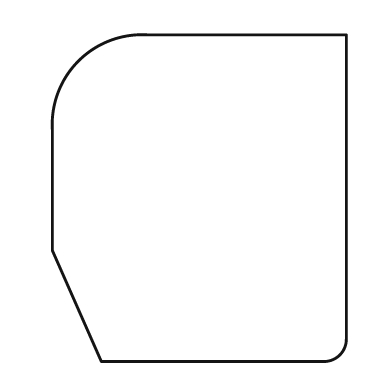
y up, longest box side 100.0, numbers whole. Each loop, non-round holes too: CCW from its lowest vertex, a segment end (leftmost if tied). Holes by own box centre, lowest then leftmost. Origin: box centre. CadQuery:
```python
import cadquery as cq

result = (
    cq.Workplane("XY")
    .moveTo(-30.0, -50.0)
    .lineTo(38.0, -50.0)
    .threePointArc((43.0, -48.0), (45.0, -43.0))
    .lineTo(45.0, 50.0)
    .lineTo(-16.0, 50.0)
    .threePointArc((-37.0, 42.0), (-45.0, 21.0))
    .lineTo(-45.0, -16.0)
    .close()
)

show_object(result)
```